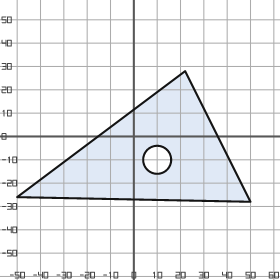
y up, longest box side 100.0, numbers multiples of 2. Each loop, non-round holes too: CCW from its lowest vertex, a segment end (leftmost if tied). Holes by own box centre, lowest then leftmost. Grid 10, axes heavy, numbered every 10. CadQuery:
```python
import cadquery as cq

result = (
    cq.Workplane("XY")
    .moveTo(50.0, -28.0)
    .lineTo(22.0, 28.0)
    .lineTo(-50.0, -26.0)
    .close()
    .moveTo(10.0, -10.0)
    .circle(6.0)
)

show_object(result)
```